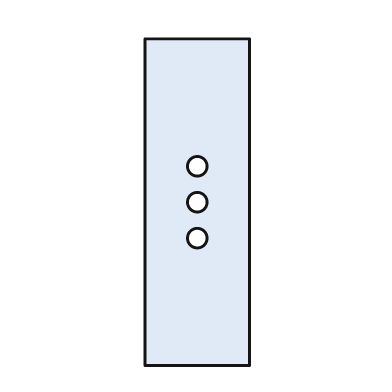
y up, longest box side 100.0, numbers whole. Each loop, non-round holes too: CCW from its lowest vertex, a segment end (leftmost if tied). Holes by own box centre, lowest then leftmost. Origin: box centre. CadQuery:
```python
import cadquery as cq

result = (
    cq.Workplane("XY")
    .moveTo(-16.0, -50.0)
    .lineTo(16.0, -50.0)
    .lineTo(16.0, 50.0)
    .lineTo(-16.0, 50.0)
    .close()
    .moveTo(0.0, -11.0)
    .circle(3.0)
    .moveTo(0.0, 0.0)
    .circle(3.0)
    .moveTo(0.0, 11.0)
    .circle(3.0)
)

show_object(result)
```